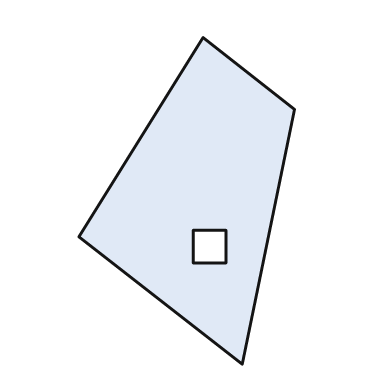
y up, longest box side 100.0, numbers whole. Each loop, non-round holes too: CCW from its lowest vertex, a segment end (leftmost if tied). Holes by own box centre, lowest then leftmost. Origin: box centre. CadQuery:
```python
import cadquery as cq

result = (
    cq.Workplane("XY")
    .moveTo(17.0, -50.0)
    .lineTo(33.0, 28.0)
    .lineTo(5.0, 50.0)
    .lineTo(-33.0, -11.0)
    .close()
    .moveTo(2.0, -19.0)
    .lineTo(12.0, -19.0)
    .lineTo(12.0, -9.0)
    .lineTo(2.0, -9.0)
    .close()
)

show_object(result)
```